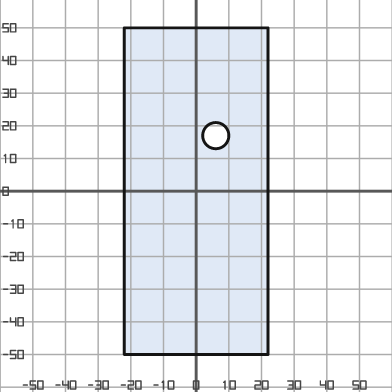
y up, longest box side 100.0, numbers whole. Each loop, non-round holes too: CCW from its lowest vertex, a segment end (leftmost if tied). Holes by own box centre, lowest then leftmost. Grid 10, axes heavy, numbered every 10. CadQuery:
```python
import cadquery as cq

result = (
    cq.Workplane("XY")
    .moveTo(-22.0, -50.0)
    .lineTo(22.0, -50.0)
    .lineTo(22.0, 50.0)
    .lineTo(-22.0, 50.0)
    .close()
    .moveTo(6.0, 17.0)
    .circle(4.0)
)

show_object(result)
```